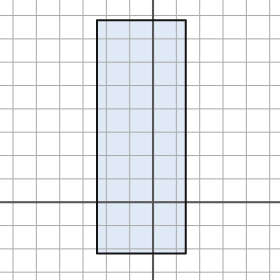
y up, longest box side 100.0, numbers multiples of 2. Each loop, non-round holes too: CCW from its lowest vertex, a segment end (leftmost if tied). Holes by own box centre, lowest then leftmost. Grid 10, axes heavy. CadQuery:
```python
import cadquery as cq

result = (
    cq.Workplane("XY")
    .moveTo(-24.0, -22.0)
    .lineTo(14.0, -22.0)
    .lineTo(14.0, 78.0)
    .lineTo(-24.0, 78.0)
    .close()
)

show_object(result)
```